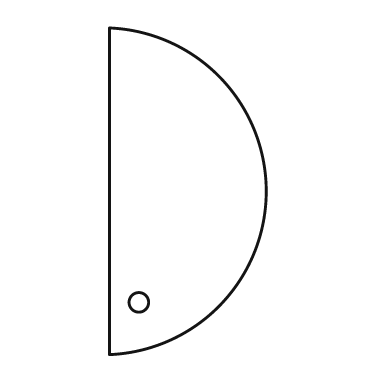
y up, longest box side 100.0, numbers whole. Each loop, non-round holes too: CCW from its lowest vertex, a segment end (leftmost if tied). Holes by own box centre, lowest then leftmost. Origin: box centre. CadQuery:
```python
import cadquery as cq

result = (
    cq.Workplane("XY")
    .moveTo(-24.0, -50.0)
    .threePointArc((24.0, 0.0), (-24.0, 50.0))
    .close()
    .moveTo(-15.0, -34.0)
    .circle(3.0)
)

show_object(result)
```